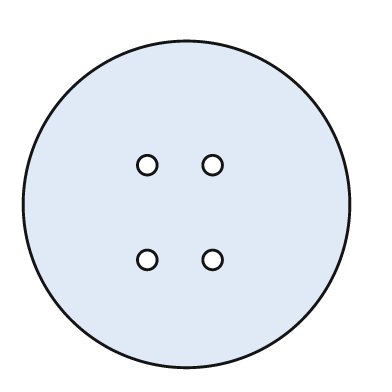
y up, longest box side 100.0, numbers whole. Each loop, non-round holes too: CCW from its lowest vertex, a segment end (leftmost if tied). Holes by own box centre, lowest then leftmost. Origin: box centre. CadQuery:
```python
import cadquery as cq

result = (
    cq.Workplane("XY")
    .moveTo(0.0, 0.0)
    .circle(50.0)
    .moveTo(-12.0, -17.0)
    .circle(3.0)
    .moveTo(8.0, -17.0)
    .circle(3.0)
    .moveTo(-12.0, 12.0)
    .circle(3.0)
    .moveTo(8.0, 12.0)
    .circle(3.0)
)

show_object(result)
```